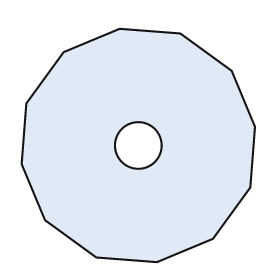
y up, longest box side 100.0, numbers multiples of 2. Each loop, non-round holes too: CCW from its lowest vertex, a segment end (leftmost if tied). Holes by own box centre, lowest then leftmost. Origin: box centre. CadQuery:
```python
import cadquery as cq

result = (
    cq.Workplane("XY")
    .moveTo(8.0, -50.0)
    .lineTo(32.0, -40.0)
    .lineTo(48.0, -18.0)
    .lineTo(50.0, 8.0)
    .lineTo(40.0, 32.0)
    .lineTo(18.0, 48.0)
    .lineTo(-8.0, 50.0)
    .lineTo(-32.0, 40.0)
    .lineTo(-48.0, 18.0)
    .lineTo(-50.0, -8.0)
    .lineTo(-40.0, -32.0)
    .lineTo(-18.0, -48.0)
    .close()
    .moveTo(0.0, 0.0)
    .circle(10.0)
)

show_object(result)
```